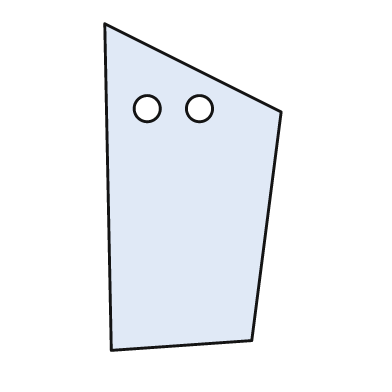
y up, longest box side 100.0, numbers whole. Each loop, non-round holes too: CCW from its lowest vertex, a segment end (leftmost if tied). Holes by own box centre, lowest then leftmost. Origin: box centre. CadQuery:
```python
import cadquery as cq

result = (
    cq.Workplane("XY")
    .moveTo(-25.0, -50.0)
    .lineTo(18.0, -47.0)
    .lineTo(27.0, 23.0)
    .lineTo(-27.0, 50.0)
    .close()
    .moveTo(-14.0, 24.0)
    .circle(4.0)
    .moveTo(2.0, 24.0)
    .circle(4.0)
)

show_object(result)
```